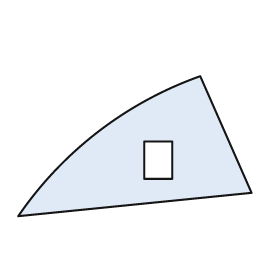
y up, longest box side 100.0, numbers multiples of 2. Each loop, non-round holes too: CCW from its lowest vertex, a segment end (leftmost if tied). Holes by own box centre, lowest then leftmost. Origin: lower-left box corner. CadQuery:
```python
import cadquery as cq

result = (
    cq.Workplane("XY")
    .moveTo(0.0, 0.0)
    .lineTo(100.0, 10.0)
    .lineTo(78.0, 60.0)
    .threePointArc((34.0, 36.0), (0.0, 0.0))
    .close()
    .moveTo(54.0, 16.0)
    .lineTo(66.0, 16.0)
    .lineTo(66.0, 32.0)
    .lineTo(54.0, 32.0)
    .close()
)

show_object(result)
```